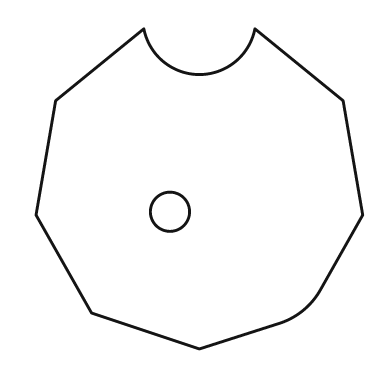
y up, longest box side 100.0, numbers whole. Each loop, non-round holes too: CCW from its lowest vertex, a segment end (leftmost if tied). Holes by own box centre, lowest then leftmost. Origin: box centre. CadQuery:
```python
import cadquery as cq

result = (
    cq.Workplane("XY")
    .moveTo(0.0, -49.0)
    .lineTo(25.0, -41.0)
    .threePointArc((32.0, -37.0), (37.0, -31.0))
    .lineTo(50.0, -8.0)
    .lineTo(44.0, 27.0)
    .lineTo(17.0, 49.0)
    .threePointArc((0.0, 35.0), (-17.0, 49.0))
    .lineTo(-44.0, 27.0)
    .lineTo(-50.0, -8.0)
    .lineTo(-33.0, -38.0)
    .close()
    .moveTo(-9.0, -7.0)
    .circle(6.0)
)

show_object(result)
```